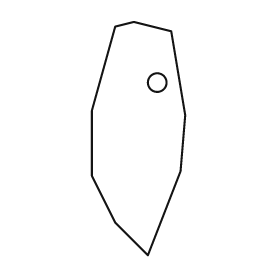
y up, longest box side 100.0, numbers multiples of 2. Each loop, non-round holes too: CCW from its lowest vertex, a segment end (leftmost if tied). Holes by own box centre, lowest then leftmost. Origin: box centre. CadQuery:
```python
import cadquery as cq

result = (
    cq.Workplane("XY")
    .moveTo(4.0, -50.0)
    .lineTo(18.0, -14.0)
    .lineTo(20.0, 10.0)
    .lineTo(14.0, 46.0)
    .lineTo(-2.0, 50.0)
    .lineTo(-10.0, 48.0)
    .lineTo(-20.0, 12.0)
    .lineTo(-20.0, -16.0)
    .lineTo(-10.0, -36.0)
    .close()
    .moveTo(8.0, 24.0)
    .circle(4.0)
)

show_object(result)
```